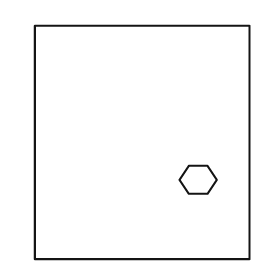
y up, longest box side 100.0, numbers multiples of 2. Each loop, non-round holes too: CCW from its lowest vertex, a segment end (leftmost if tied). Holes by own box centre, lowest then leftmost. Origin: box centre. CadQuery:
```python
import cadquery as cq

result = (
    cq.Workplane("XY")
    .moveTo(-46.0, -50.0)
    .lineTo(46.0, -50.0)
    .lineTo(46.0, 50.0)
    .lineTo(-46.0, 50.0)
    .close()
    .moveTo(20.0, -22.0)
    .lineTo(28.0, -22.0)
    .lineTo(32.0, -16.0)
    .lineTo(28.0, -10.0)
    .lineTo(20.0, -10.0)
    .lineTo(16.0, -16.0)
    .close()
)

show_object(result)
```